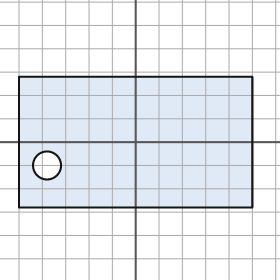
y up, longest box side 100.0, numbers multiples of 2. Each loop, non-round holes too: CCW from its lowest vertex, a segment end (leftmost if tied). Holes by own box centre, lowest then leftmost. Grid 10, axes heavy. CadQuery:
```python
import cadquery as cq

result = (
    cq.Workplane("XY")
    .moveTo(-50.0, -28.0)
    .lineTo(50.0, -28.0)
    .lineTo(50.0, 28.0)
    .lineTo(-50.0, 28.0)
    .close()
    .moveTo(-38.0, -10.0)
    .circle(6.0)
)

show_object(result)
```